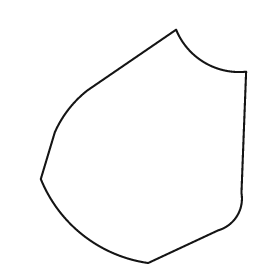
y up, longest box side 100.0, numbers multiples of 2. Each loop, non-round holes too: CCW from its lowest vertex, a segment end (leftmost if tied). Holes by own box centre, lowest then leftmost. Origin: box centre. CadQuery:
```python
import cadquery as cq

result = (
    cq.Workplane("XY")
    .moveTo(2.0, -50.0)
    .lineTo(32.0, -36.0)
    .threePointArc((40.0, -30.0), (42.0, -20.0))
    .lineTo(44.0, 32.0)
    .threePointArc((26.0, 36.0), (14.0, 50.0))
    .lineTo(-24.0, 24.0)
    .threePointArc((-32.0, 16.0), (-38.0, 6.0))
    .lineTo(-44.0, -14.0)
    .threePointArc((-26.0, -38.0), (2.0, -50.0))
    .close()
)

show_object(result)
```